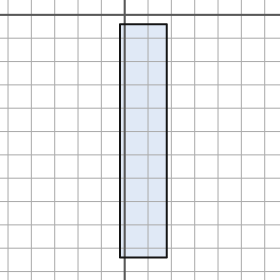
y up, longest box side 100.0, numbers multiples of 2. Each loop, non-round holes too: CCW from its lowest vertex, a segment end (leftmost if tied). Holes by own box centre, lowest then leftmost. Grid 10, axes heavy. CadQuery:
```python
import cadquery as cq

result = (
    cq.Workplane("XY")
    .moveTo(-2.0, -104.0)
    .lineTo(18.0, -104.0)
    .lineTo(18.0, -4.0)
    .lineTo(-2.0, -4.0)
    .close()
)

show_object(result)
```